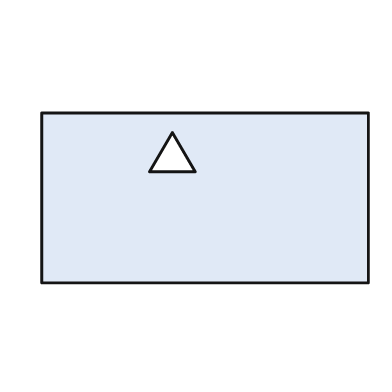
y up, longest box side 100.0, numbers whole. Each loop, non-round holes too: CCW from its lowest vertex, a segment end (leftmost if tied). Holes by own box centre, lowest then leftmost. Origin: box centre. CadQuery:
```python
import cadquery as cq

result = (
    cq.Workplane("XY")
    .moveTo(-50.0, -26.0)
    .lineTo(50.0, -26.0)
    .lineTo(50.0, 26.0)
    .lineTo(-50.0, 26.0)
    .close()
    .moveTo(-17.0, 8.0)
    .lineTo(-3.0, 8.0)
    .lineTo(-10.0, 20.0)
    .close()
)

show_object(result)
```